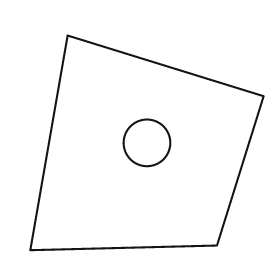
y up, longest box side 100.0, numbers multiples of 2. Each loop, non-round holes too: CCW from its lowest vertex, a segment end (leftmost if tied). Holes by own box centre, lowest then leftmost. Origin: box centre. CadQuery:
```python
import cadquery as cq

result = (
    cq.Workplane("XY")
    .moveTo(-50.0, -46.0)
    .lineTo(30.0, -44.0)
    .lineTo(50.0, 20.0)
    .lineTo(-34.0, 46.0)
    .close()
    .moveTo(0.0, 0.0)
    .circle(10.0)
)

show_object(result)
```